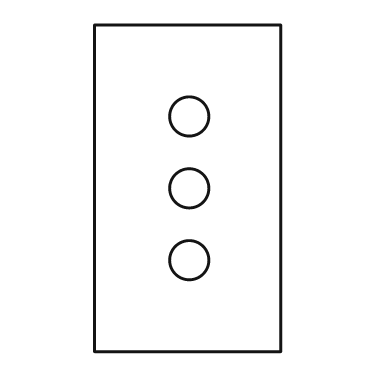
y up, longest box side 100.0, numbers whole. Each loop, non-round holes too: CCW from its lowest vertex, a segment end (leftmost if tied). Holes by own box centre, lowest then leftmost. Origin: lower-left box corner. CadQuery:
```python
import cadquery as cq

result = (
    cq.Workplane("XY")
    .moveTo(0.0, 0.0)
    .lineTo(57.0, 0.0)
    .lineTo(57.0, 100.0)
    .lineTo(0.0, 100.0)
    .close()
    .moveTo(29.0, 28.0)
    .circle(6.0)
    .moveTo(29.0, 50.0)
    .circle(6.0)
    .moveTo(29.0, 72.0)
    .circle(6.0)
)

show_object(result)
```